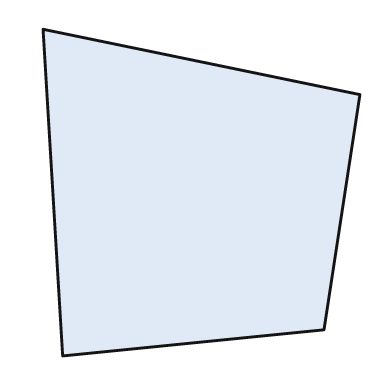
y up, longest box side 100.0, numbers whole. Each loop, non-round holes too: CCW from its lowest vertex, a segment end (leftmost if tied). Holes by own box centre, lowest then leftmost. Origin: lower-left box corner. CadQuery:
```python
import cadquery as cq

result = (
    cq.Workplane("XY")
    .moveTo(6.0, 0.0)
    .lineTo(86.0, 8.0)
    .lineTo(97.0, 80.0)
    .lineTo(0.0, 100.0)
    .close()
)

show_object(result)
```